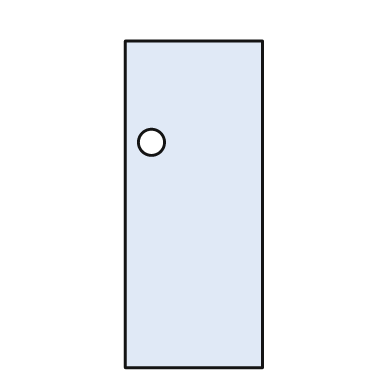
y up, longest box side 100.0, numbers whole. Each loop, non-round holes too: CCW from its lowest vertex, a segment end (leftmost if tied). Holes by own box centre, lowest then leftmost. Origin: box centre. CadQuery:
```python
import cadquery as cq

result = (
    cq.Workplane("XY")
    .moveTo(-21.0, -50.0)
    .lineTo(21.0, -50.0)
    .lineTo(21.0, 50.0)
    .lineTo(-21.0, 50.0)
    .close()
    .moveTo(-13.0, 19.0)
    .circle(4.0)
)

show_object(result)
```